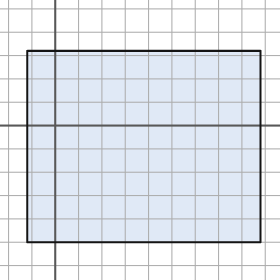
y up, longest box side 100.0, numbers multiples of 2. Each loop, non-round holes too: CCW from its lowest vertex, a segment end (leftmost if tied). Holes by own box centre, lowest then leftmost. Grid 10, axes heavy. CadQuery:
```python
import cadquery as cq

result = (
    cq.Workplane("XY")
    .moveTo(-12.0, -50.0)
    .lineTo(88.0, -50.0)
    .lineTo(88.0, 32.0)
    .lineTo(-12.0, 32.0)
    .close()
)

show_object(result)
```